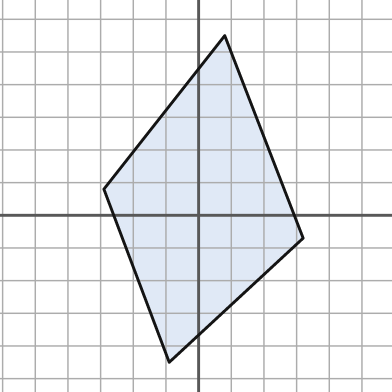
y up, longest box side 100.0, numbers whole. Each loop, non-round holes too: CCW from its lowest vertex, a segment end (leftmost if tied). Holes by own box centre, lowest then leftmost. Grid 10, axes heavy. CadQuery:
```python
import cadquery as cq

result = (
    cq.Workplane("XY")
    .moveTo(-9.0, -45.0)
    .lineTo(32.0, -7.0)
    .lineTo(8.0, 55.0)
    .lineTo(-29.0, 8.0)
    .close()
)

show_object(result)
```